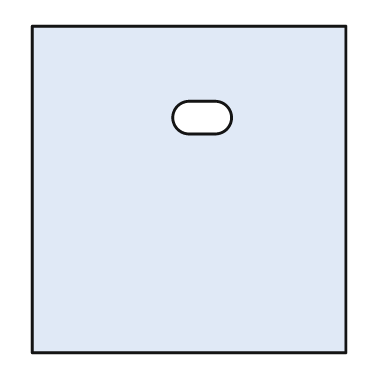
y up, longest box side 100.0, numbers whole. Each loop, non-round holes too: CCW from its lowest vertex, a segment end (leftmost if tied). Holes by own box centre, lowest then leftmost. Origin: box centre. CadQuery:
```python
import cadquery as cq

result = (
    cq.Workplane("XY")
    .moveTo(-48.0, -50.0)
    .lineTo(48.0, -50.0)
    .lineTo(48.0, 50.0)
    .lineTo(-48.0, 50.0)
    .close()
    .moveTo(0.0, 17.0)
    .lineTo(8.0, 17.0)
    .threePointArc((13.0, 22.0), (8.0, 27.0))
    .lineTo(0.0, 27.0)
    .threePointArc((-5.0, 22.0), (0.0, 17.0))
    .close()
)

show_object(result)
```